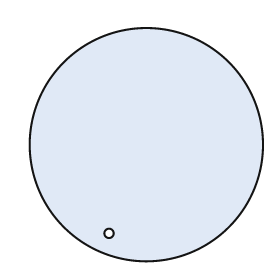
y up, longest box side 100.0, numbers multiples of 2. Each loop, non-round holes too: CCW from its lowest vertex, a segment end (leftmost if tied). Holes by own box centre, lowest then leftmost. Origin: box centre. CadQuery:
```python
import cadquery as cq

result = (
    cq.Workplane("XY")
    .moveTo(0.0, 0.0)
    .circle(50.0)
    .moveTo(-16.0, -38.0)
    .circle(2.0)
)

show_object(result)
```